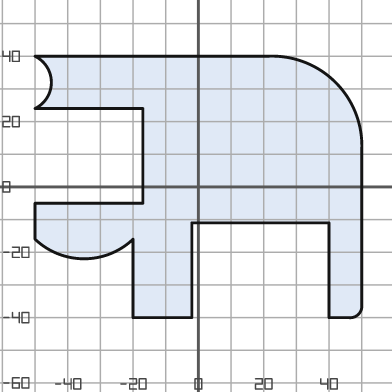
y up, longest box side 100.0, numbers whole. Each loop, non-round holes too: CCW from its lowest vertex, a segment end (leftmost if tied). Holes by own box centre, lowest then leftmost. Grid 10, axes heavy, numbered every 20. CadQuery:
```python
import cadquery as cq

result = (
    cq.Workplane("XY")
    .moveTo(-20.0, -40.0)
    .lineTo(-2.0, -40.0)
    .lineTo(-2.0, -11.0)
    .lineTo(40.0, -11.0)
    .lineTo(40.0, -40.0)
    .lineTo(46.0, -40.0)
    .threePointArc((49.0, -39.0), (50.0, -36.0))
    .lineTo(50.0, 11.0)
    .threePointArc((42.0, 32.0), (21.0, 40.0))
    .lineTo(-50.0, 40.0)
    .threePointArc((-45.0, 32.0), (-50.0, 24.0))
    .lineTo(-17.0, 24.0)
    .lineTo(-17.0, -5.0)
    .lineTo(-50.0, -5.0)
    .lineTo(-50.0, -16.0)
    .threePointArc((-35.0, -22.0), (-20.0, -16.0))
    .close()
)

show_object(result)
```